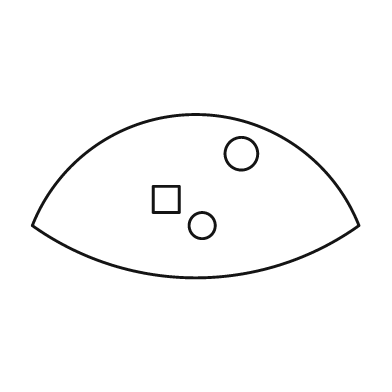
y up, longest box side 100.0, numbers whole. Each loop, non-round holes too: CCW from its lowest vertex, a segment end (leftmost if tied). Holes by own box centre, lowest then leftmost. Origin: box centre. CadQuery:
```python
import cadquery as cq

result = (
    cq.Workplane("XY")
    .moveTo(-50.0, -9.0)
    .threePointArc((0.0, -25.0), (50.0, -9.0))
    .threePointArc((0.0, 25.0), (-50.0, -9.0))
    .close()
    .moveTo(2.0, -9.0)
    .circle(4.0)
    .moveTo(-13.0, -5.0)
    .lineTo(-5.0, -5.0)
    .lineTo(-5.0, 3.0)
    .lineTo(-13.0, 3.0)
    .close()
    .moveTo(14.0, 13.0)
    .circle(5.0)
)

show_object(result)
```